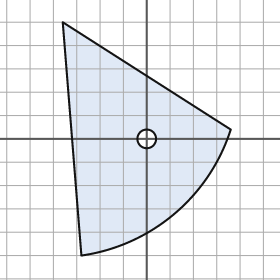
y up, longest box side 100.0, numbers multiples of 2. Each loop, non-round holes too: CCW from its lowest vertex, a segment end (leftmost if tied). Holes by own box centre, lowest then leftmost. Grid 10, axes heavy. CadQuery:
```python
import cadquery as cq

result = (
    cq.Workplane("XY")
    .moveTo(-28.0, -50.0)
    .threePointArc((12.0, -32.0), (36.0, 4.0))
    .lineTo(-36.0, 50.0)
    .close()
    .moveTo(0.0, 0.0)
    .circle(4.0)
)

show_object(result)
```